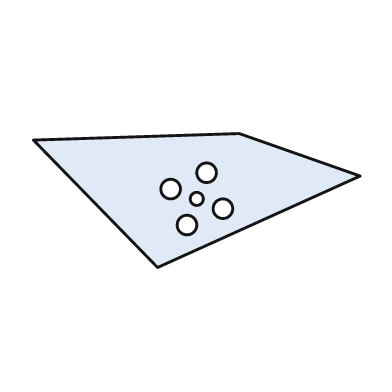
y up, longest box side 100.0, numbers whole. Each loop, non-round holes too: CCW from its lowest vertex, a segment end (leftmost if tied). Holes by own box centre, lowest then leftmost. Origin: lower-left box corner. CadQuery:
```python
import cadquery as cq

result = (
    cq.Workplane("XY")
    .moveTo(38.0, 0.0)
    .lineTo(100.0, 28.0)
    .lineTo(63.0, 41.0)
    .lineTo(0.0, 39.0)
    .close()
    .moveTo(47.0, 13.0)
    .circle(3.0)
    .moveTo(58.0, 18.0)
    .circle(3.0)
    .moveTo(50.0, 21.0)
    .circle(2.0)
    .moveTo(42.0, 24.0)
    .circle(3.0)
    .moveTo(53.0, 29.0)
    .circle(3.0)
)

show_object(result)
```